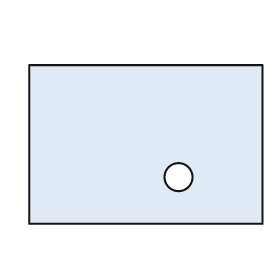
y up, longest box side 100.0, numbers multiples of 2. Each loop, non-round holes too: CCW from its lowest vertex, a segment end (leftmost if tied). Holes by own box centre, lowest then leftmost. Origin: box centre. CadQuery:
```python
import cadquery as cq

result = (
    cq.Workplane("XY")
    .moveTo(-50.0, -34.0)
    .lineTo(50.0, -34.0)
    .lineTo(50.0, 34.0)
    .lineTo(-50.0, 34.0)
    .close()
    .moveTo(14.0, -14.0)
    .circle(6.0)
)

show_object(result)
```